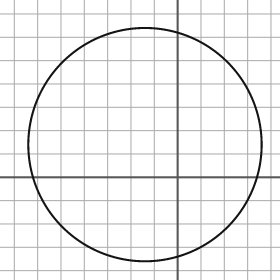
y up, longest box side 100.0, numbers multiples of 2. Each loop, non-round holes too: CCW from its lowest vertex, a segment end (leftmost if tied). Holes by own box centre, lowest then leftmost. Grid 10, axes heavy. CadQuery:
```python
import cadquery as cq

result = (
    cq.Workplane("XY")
    .moveTo(-14.0, 14.0)
    .circle(50.0)
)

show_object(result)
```